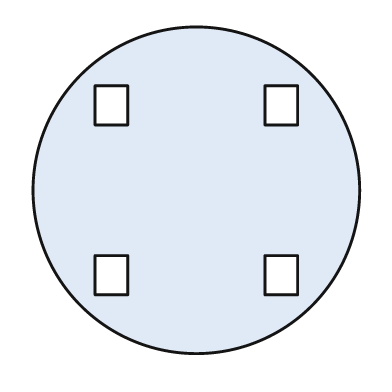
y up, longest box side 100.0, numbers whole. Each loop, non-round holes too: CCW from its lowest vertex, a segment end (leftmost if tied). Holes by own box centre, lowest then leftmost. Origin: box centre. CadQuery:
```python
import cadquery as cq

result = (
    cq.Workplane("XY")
    .moveTo(0.0, 0.0)
    .circle(50.0)
    .moveTo(-31.0, -32.0)
    .lineTo(-21.0, -32.0)
    .lineTo(-21.0, -20.0)
    .lineTo(-31.0, -20.0)
    .close()
    .moveTo(21.0, -32.0)
    .lineTo(31.0, -32.0)
    .lineTo(31.0, -20.0)
    .lineTo(21.0, -20.0)
    .close()
    .moveTo(-31.0, 20.0)
    .lineTo(-21.0, 20.0)
    .lineTo(-21.0, 32.0)
    .lineTo(-31.0, 32.0)
    .close()
    .moveTo(21.0, 20.0)
    .lineTo(31.0, 20.0)
    .lineTo(31.0, 32.0)
    .lineTo(21.0, 32.0)
    .close()
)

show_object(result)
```